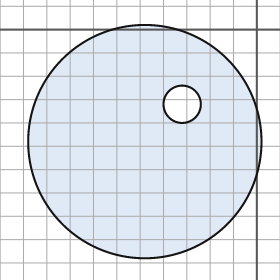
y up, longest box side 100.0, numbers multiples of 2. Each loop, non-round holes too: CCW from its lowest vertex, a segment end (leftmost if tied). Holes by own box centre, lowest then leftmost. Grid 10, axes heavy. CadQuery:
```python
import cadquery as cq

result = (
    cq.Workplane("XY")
    .moveTo(-48.0, -48.0)
    .circle(50.0)
    .moveTo(-32.0, -32.0)
    .circle(8.0)
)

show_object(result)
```